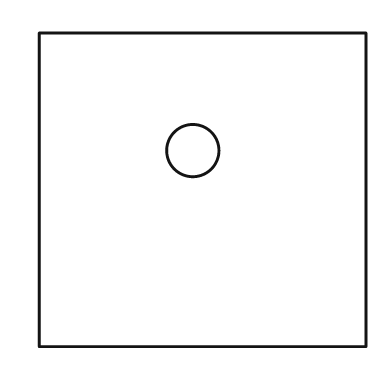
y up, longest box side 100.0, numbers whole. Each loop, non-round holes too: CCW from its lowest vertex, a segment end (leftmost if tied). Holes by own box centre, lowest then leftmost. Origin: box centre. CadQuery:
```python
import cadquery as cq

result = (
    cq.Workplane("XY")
    .moveTo(-50.0, -48.0)
    .lineTo(50.0, -48.0)
    .lineTo(50.0, 48.0)
    .lineTo(-50.0, 48.0)
    .close()
    .moveTo(-3.0, 12.0)
    .circle(8.0)
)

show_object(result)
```